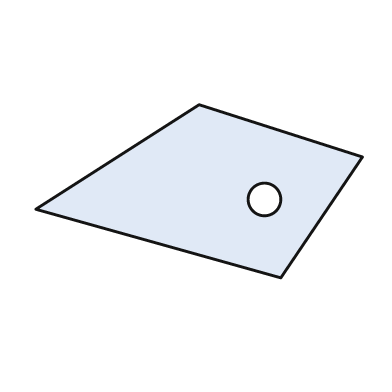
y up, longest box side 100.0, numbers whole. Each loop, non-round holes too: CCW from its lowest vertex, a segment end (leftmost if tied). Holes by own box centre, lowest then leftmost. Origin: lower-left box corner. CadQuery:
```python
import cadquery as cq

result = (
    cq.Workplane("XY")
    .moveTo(75.0, 0.0)
    .lineTo(100.0, 37.0)
    .lineTo(50.0, 53.0)
    .lineTo(0.0, 21.0)
    .close()
    .moveTo(70.0, 24.0)
    .circle(5.0)
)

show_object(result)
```